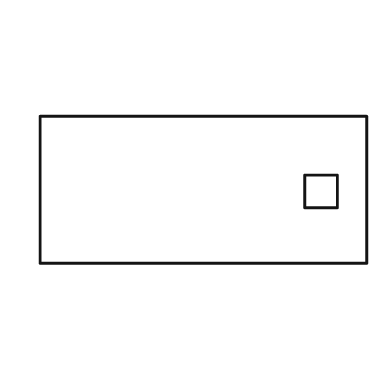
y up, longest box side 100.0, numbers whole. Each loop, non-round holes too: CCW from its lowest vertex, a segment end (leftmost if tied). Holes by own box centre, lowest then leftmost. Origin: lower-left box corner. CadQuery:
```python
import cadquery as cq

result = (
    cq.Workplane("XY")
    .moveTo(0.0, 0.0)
    .lineTo(100.0, 0.0)
    .lineTo(100.0, 45.0)
    .lineTo(0.0, 45.0)
    .close()
    .moveTo(81.0, 17.0)
    .lineTo(91.0, 17.0)
    .lineTo(91.0, 27.0)
    .lineTo(81.0, 27.0)
    .close()
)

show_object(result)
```